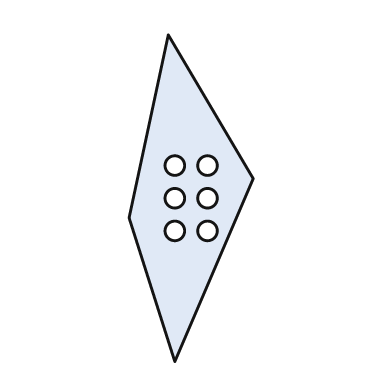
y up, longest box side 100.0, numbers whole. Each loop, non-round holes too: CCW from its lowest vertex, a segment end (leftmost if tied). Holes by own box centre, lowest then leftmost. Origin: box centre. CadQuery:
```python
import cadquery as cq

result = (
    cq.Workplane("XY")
    .moveTo(-5.0, -50.0)
    .lineTo(19.0, 6.0)
    .lineTo(-7.0, 50.0)
    .lineTo(-19.0, -6.0)
    .close()
    .moveTo(-5.0, -10.0)
    .circle(3.0)
    .moveTo(5.0, -10.0)
    .circle(3.0)
    .moveTo(-5.0, 0.0)
    .circle(3.0)
    .moveTo(5.0, 0.0)
    .circle(3.0)
    .moveTo(-5.0, 10.0)
    .circle(3.0)
    .moveTo(5.0, 10.0)
    .circle(3.0)
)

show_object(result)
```